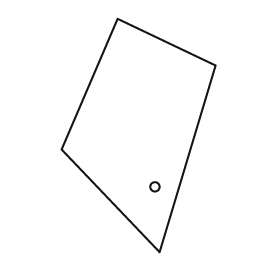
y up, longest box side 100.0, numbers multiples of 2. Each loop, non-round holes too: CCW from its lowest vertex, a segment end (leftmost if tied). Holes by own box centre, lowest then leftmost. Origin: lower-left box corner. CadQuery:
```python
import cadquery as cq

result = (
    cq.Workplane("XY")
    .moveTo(42.0, 0.0)
    .lineTo(66.0, 80.0)
    .lineTo(24.0, 100.0)
    .lineTo(0.0, 44.0)
    .close()
    .moveTo(40.0, 28.0)
    .circle(2.0)
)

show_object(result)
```